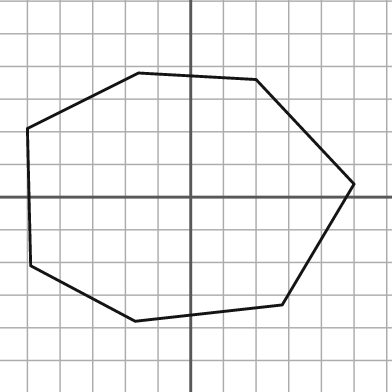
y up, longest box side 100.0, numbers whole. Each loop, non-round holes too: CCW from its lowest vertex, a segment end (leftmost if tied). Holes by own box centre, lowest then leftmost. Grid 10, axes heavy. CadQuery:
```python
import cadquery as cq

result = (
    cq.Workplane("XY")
    .moveTo(-17.0, -38.0)
    .lineTo(28.0, -33.0)
    .lineTo(50.0, 4.0)
    .lineTo(20.0, 36.0)
    .lineTo(-16.0, 38.0)
    .lineTo(-50.0, 21.0)
    .lineTo(-49.0, -21.0)
    .close()
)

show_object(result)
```